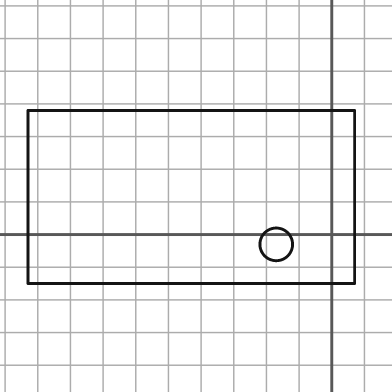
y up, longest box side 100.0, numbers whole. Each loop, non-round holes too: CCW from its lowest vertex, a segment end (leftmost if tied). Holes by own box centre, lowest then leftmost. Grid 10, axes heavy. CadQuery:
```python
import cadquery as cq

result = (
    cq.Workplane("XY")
    .moveTo(-93.0, -15.0)
    .lineTo(7.0, -15.0)
    .lineTo(7.0, 38.0)
    .lineTo(-93.0, 38.0)
    .close()
    .moveTo(-17.0, -3.0)
    .circle(5.0)
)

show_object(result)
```